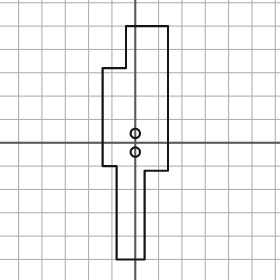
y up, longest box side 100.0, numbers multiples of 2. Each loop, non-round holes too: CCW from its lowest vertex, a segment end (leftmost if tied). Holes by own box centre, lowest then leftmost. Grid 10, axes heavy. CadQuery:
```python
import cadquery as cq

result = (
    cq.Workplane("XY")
    .moveTo(-8.0, -50.0)
    .lineTo(4.0, -50.0)
    .lineTo(4.0, -12.0)
    .lineTo(14.0, -12.0)
    .lineTo(14.0, 50.0)
    .lineTo(-4.0, 50.0)
    .lineTo(-4.0, 32.0)
    .lineTo(-14.0, 32.0)
    .lineTo(-14.0, -10.0)
    .lineTo(-8.0, -10.0)
    .close()
    .moveTo(0.0, -4.0)
    .circle(2.0)
    .moveTo(0.0, 4.0)
    .circle(2.0)
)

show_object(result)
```